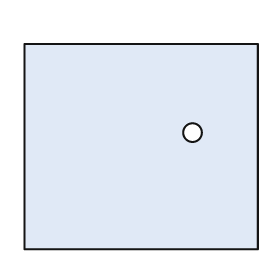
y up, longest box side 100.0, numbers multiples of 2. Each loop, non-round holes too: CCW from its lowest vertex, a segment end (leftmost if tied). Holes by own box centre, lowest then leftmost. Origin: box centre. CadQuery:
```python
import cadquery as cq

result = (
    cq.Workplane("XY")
    .moveTo(-50.0, -44.0)
    .lineTo(50.0, -44.0)
    .lineTo(50.0, 44.0)
    .lineTo(-50.0, 44.0)
    .close()
    .moveTo(22.0, 6.0)
    .circle(4.0)
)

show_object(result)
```